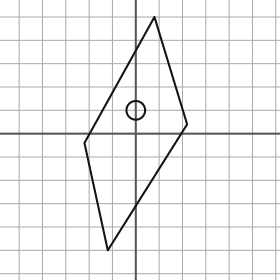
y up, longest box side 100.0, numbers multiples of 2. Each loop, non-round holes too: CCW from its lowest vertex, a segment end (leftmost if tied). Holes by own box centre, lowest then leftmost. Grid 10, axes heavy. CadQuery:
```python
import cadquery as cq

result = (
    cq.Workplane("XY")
    .moveTo(-12.0, -50.0)
    .lineTo(22.0, 4.0)
    .lineTo(8.0, 50.0)
    .lineTo(-22.0, -4.0)
    .close()
    .moveTo(0.0, 10.0)
    .circle(4.0)
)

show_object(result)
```